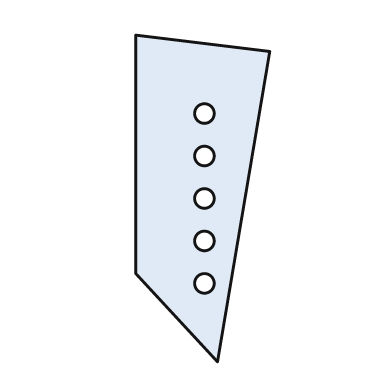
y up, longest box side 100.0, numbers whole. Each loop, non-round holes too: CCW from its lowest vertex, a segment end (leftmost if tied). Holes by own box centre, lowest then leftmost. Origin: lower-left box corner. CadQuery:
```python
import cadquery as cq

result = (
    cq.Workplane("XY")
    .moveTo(25.0, 0.0)
    .lineTo(41.0, 95.0)
    .lineTo(0.0, 100.0)
    .lineTo(0.0, 27.0)
    .close()
    .moveTo(21.0, 24.0)
    .circle(3.0)
    .moveTo(21.0, 37.0)
    .circle(3.0)
    .moveTo(21.0, 50.0)
    .circle(3.0)
    .moveTo(21.0, 63.0)
    .circle(3.0)
    .moveTo(21.0, 76.0)
    .circle(3.0)
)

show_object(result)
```